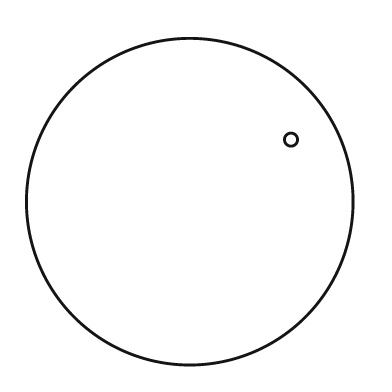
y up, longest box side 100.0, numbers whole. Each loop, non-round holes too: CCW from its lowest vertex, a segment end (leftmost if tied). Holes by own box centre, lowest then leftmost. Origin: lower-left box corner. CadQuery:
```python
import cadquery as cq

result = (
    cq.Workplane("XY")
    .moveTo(50.0, 50.0)
    .circle(50.0)
    .moveTo(81.0, 69.0)
    .circle(2.0)
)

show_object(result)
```